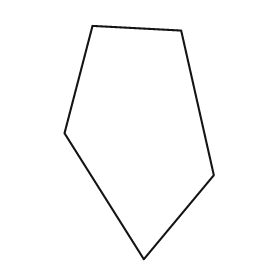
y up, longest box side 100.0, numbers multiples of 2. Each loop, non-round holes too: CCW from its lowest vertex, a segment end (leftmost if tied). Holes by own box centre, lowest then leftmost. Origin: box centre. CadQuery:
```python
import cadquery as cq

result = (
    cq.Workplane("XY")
    .moveTo(2.0, -50.0)
    .lineTo(32.0, -14.0)
    .lineTo(18.0, 48.0)
    .lineTo(-20.0, 50.0)
    .lineTo(-32.0, 4.0)
    .close()
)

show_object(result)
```